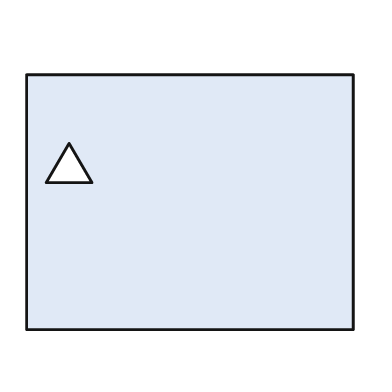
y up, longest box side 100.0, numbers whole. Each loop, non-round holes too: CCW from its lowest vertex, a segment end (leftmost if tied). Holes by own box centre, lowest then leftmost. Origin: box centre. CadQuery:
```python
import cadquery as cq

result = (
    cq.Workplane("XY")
    .moveTo(-50.0, -39.0)
    .lineTo(50.0, -39.0)
    .lineTo(50.0, 39.0)
    .lineTo(-50.0, 39.0)
    .close()
    .moveTo(-44.0, 6.0)
    .lineTo(-30.0, 6.0)
    .lineTo(-37.0, 18.0)
    .close()
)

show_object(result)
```